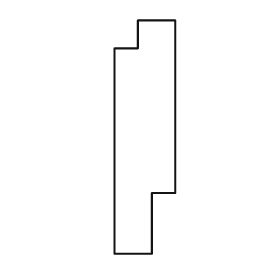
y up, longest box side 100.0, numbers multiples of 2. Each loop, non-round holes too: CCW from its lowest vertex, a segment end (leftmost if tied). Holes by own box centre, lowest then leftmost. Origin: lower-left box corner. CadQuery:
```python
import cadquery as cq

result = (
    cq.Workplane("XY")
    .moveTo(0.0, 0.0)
    .lineTo(16.0, 0.0)
    .lineTo(16.0, 26.0)
    .lineTo(26.0, 26.0)
    .lineTo(26.0, 100.0)
    .lineTo(10.0, 100.0)
    .lineTo(10.0, 88.0)
    .lineTo(0.0, 88.0)
    .close()
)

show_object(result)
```